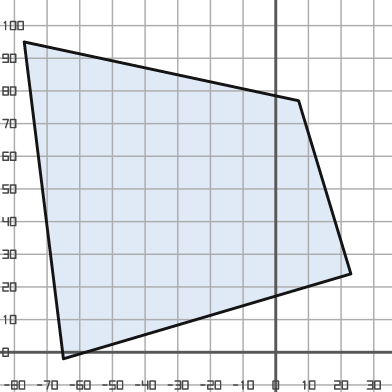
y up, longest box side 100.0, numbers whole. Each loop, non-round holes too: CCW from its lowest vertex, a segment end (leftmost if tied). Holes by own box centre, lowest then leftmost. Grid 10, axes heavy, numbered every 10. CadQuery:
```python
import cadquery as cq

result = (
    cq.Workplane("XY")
    .moveTo(-65.0, -2.0)
    .lineTo(23.0, 24.0)
    .lineTo(7.0, 77.0)
    .lineTo(-77.0, 95.0)
    .close()
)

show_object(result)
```